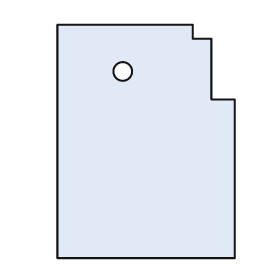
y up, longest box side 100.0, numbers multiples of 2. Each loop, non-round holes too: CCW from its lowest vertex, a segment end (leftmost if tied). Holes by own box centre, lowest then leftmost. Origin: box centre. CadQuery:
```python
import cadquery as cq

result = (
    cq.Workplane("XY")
    .moveTo(-38.0, -50.0)
    .lineTo(38.0, -50.0)
    .lineTo(38.0, 18.0)
    .lineTo(28.0, 18.0)
    .lineTo(28.0, 44.0)
    .lineTo(20.0, 44.0)
    .lineTo(20.0, 50.0)
    .lineTo(-38.0, 50.0)
    .close()
    .moveTo(-10.0, 30.0)
    .circle(4.0)
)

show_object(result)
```